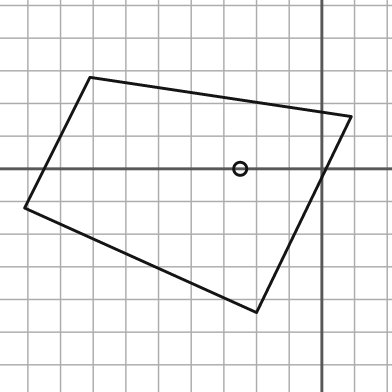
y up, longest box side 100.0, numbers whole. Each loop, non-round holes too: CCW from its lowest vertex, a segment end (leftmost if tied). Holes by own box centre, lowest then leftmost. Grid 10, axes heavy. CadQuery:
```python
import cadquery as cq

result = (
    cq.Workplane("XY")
    .moveTo(-20.0, -44.0)
    .lineTo(9.0, 16.0)
    .lineTo(-71.0, 28.0)
    .lineTo(-91.0, -12.0)
    .close()
    .moveTo(-25.0, 0.0)
    .circle(2.0)
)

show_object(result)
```